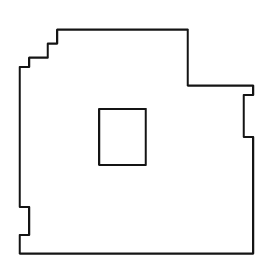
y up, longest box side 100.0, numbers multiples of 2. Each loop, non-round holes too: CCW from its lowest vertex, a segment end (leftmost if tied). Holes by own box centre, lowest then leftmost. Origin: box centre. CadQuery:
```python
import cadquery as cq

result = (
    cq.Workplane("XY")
    .moveTo(-50.0, -48.0)
    .lineTo(50.0, -48.0)
    .lineTo(50.0, 2.0)
    .lineTo(46.0, 2.0)
    .lineTo(46.0, 20.0)
    .lineTo(50.0, 20.0)
    .lineTo(50.0, 24.0)
    .lineTo(22.0, 24.0)
    .lineTo(22.0, 48.0)
    .lineTo(-34.0, 48.0)
    .lineTo(-34.0, 42.0)
    .lineTo(-38.0, 42.0)
    .lineTo(-38.0, 36.0)
    .lineTo(-46.0, 36.0)
    .lineTo(-46.0, 32.0)
    .lineTo(-50.0, 32.0)
    .lineTo(-50.0, -28.0)
    .lineTo(-46.0, -28.0)
    .lineTo(-46.0, -40.0)
    .lineTo(-50.0, -40.0)
    .close()
    .moveTo(-16.0, -10.0)
    .lineTo(4.0, -10.0)
    .lineTo(4.0, 14.0)
    .lineTo(-16.0, 14.0)
    .close()
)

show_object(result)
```